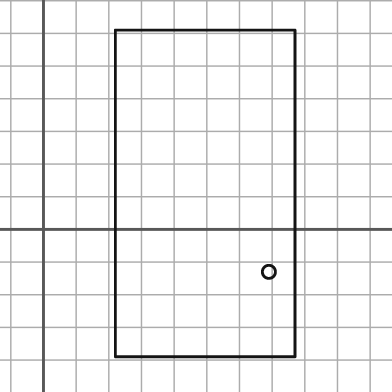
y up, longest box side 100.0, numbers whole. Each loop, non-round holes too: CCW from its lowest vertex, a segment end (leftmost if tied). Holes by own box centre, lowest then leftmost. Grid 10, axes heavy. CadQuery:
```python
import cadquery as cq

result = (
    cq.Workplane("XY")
    .moveTo(22.0, -39.0)
    .lineTo(77.0, -39.0)
    .lineTo(77.0, 61.0)
    .lineTo(22.0, 61.0)
    .close()
    .moveTo(69.0, -13.0)
    .circle(2.0)
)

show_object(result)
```